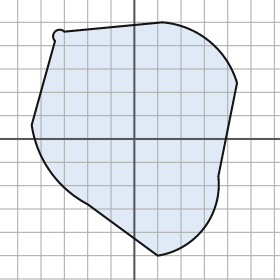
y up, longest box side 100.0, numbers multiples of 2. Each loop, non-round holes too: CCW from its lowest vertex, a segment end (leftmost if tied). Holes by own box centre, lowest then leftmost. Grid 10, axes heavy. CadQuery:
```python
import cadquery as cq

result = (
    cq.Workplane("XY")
    .moveTo(10.0, -50.0)
    .threePointArc((30.0, -38.0), (36.0, -16.0))
    .lineTo(44.0, 24.0)
    .threePointArc((32.0, 42.0), (12.0, 50.0))
    .lineTo(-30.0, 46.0)
    .threePointArc((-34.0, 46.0), (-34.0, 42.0))
    .lineTo(-44.0, 6.0)
    .threePointArc((-36.0, -14.0), (-20.0, -28.0))
    .close()
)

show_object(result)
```